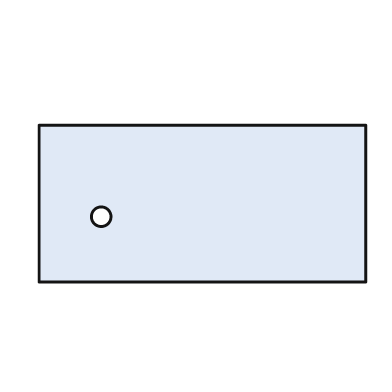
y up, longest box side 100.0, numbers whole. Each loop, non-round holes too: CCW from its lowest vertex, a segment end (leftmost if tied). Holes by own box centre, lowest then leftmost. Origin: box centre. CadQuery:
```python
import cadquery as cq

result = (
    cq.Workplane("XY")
    .moveTo(-50.0, -24.0)
    .lineTo(50.0, -24.0)
    .lineTo(50.0, 24.0)
    .lineTo(-50.0, 24.0)
    .close()
    .moveTo(-31.0, -4.0)
    .circle(3.0)
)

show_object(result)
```